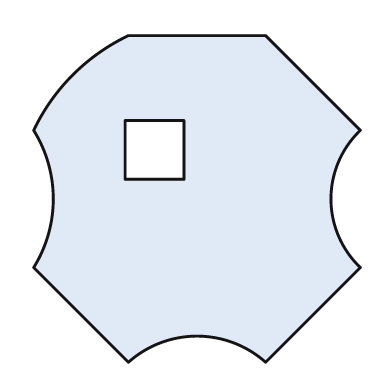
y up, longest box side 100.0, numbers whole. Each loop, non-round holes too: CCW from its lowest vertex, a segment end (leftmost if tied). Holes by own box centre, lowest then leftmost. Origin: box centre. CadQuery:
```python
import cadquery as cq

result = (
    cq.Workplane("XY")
    .moveTo(-21.0, -50.0)
    .threePointArc((0.0, -42.0), (21.0, -50.0))
    .lineTo(50.0, -21.0)
    .threePointArc((41.0, 0.0), (50.0, 21.0))
    .lineTo(21.0, 50.0)
    .lineTo(-21.0, 50.0)
    .threePointArc((-38.0, 38.0), (-50.0, 21.0))
    .threePointArc((-44.0, 0.0), (-50.0, -21.0))
    .close()
    .moveTo(-22.0, 6.0)
    .lineTo(-4.0, 6.0)
    .lineTo(-4.0, 24.0)
    .lineTo(-22.0, 24.0)
    .close()
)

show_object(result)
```